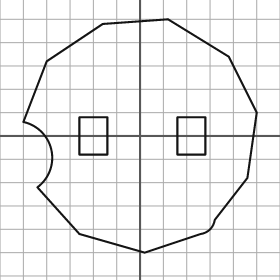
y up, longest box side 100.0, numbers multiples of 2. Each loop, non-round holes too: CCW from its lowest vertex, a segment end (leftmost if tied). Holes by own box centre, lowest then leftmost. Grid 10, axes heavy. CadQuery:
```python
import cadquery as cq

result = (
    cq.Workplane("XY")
    .moveTo(2.0, -50.0)
    .lineTo(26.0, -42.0)
    .threePointArc((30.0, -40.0), (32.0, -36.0))
    .lineTo(46.0, -18.0)
    .lineTo(50.0, 10.0)
    .lineTo(38.0, 34.0)
    .lineTo(12.0, 50.0)
    .lineTo(-16.0, 48.0)
    .lineTo(-40.0, 32.0)
    .lineTo(-50.0, 6.0)
    .threePointArc((-38.0, -6.0), (-44.0, -22.0))
    .lineTo(-26.0, -42.0)
    .close()
    .moveTo(-26.0, -8.0)
    .lineTo(-14.0, -8.0)
    .lineTo(-14.0, 8.0)
    .lineTo(-26.0, 8.0)
    .close()
    .moveTo(16.0, -8.0)
    .lineTo(28.0, -8.0)
    .lineTo(28.0, 8.0)
    .lineTo(16.0, 8.0)
    .close()
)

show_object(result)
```